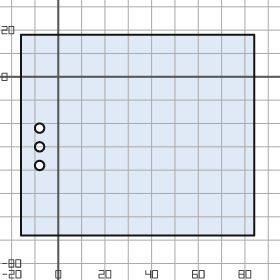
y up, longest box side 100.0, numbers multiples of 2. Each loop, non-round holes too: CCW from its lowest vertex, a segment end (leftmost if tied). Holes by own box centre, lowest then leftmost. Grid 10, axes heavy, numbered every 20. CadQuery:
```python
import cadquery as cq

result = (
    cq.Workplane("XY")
    .moveTo(-16.0, -68.0)
    .lineTo(84.0, -68.0)
    .lineTo(84.0, 18.0)
    .lineTo(-16.0, 18.0)
    .close()
    .moveTo(-8.0, -38.0)
    .circle(2.0)
    .moveTo(-8.0, -30.0)
    .circle(2.0)
    .moveTo(-8.0, -22.0)
    .circle(2.0)
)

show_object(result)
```